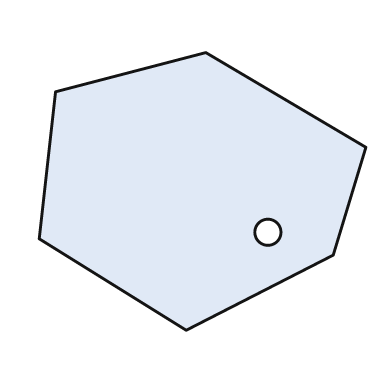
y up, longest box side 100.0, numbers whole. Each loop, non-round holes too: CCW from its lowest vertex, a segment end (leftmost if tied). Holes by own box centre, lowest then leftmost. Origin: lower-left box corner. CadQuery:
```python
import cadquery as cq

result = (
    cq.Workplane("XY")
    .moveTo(45.0, 0.0)
    .lineTo(90.0, 23.0)
    .lineTo(100.0, 56.0)
    .lineTo(51.0, 85.0)
    .lineTo(5.0, 73.0)
    .lineTo(0.0, 28.0)
    .close()
    .moveTo(70.0, 30.0)
    .circle(4.0)
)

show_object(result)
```